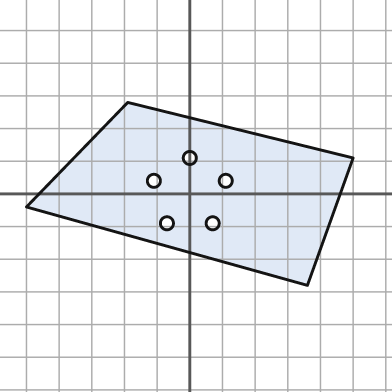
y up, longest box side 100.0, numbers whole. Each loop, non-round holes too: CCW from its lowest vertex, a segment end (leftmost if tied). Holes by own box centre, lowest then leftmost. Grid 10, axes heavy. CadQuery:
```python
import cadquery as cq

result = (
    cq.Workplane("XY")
    .moveTo(36.0, -28.0)
    .lineTo(50.0, 11.0)
    .lineTo(-19.0, 28.0)
    .lineTo(-50.0, -4.0)
    .close()
    .moveTo(-7.0, -9.0)
    .circle(2.0)
    .moveTo(7.0, -9.0)
    .circle(2.0)
    .moveTo(-11.0, 4.0)
    .circle(2.0)
    .moveTo(11.0, 4.0)
    .circle(2.0)
    .moveTo(0.0, 11.0)
    .circle(2.0)
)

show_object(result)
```